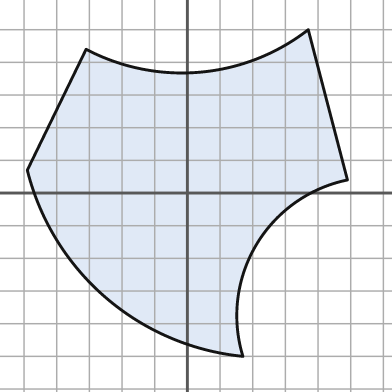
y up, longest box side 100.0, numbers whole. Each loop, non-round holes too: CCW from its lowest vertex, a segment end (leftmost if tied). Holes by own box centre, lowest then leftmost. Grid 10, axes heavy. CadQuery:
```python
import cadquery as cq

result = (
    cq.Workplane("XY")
    .moveTo(17.0, -50.0)
    .threePointArc((21.0, -16.0), (49.0, 4.0))
    .lineTo(37.0, 50.0)
    .threePointArc((4.0, 37.0), (-31.0, 44.0))
    .lineTo(-49.0, 7.0)
    .threePointArc((-25.0, -32.0), (17.0, -50.0))
    .close()
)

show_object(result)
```